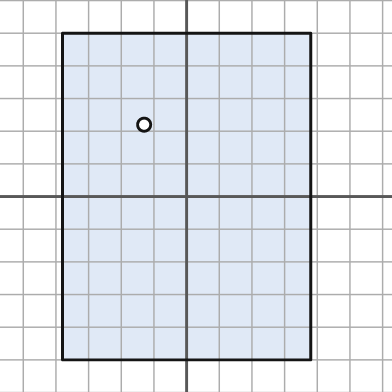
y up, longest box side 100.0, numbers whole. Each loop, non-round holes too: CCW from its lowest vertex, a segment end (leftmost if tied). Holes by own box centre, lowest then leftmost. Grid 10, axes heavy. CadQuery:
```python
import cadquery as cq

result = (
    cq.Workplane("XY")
    .moveTo(-38.0, -50.0)
    .lineTo(38.0, -50.0)
    .lineTo(38.0, 50.0)
    .lineTo(-38.0, 50.0)
    .close()
    .moveTo(-13.0, 22.0)
    .circle(2.0)
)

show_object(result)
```